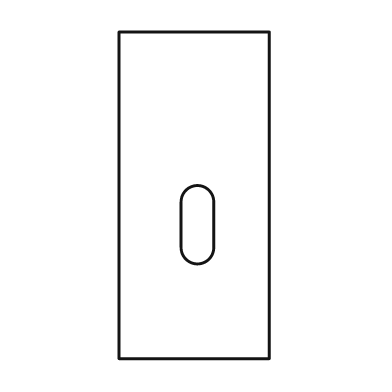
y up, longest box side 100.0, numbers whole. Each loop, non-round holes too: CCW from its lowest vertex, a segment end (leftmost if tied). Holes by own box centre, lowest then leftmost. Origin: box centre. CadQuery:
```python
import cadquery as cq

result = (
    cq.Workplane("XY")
    .moveTo(-23.0, -50.0)
    .lineTo(23.0, -50.0)
    .lineTo(23.0, 50.0)
    .lineTo(-23.0, 50.0)
    .close()
    .moveTo(-4.0, -16.0)
    .threePointArc((1.0, -21.0), (6.0, -16.0))
    .lineTo(6.0, -2.0)
    .threePointArc((1.0, 3.0), (-4.0, -2.0))
    .close()
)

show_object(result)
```